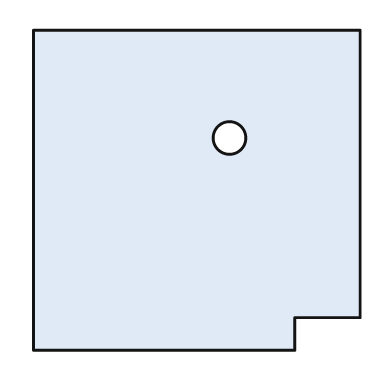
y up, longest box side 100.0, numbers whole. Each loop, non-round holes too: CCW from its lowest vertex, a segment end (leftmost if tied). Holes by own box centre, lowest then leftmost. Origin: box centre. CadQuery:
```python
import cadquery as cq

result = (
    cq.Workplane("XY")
    .moveTo(-50.0, -49.0)
    .lineTo(30.0, -49.0)
    .lineTo(30.0, -39.0)
    .lineTo(50.0, -39.0)
    .lineTo(50.0, 49.0)
    .lineTo(-50.0, 49.0)
    .close()
    .moveTo(10.0, 16.0)
    .circle(5.0)
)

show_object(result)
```